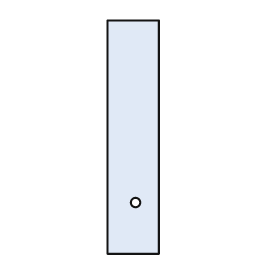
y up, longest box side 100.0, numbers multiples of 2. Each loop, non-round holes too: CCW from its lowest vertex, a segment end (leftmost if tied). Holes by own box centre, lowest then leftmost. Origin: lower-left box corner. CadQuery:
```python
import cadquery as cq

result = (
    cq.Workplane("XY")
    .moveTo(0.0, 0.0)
    .lineTo(22.0, 0.0)
    .lineTo(22.0, 100.0)
    .lineTo(0.0, 100.0)
    .close()
    .moveTo(12.0, 22.0)
    .circle(2.0)
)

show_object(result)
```